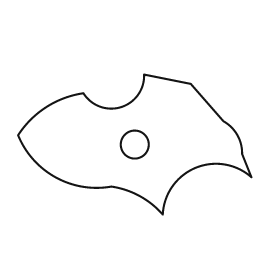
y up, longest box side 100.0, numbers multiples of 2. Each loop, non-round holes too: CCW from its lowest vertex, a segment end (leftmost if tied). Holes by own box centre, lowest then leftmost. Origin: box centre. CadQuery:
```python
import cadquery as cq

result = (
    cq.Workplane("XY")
    .moveTo(12.0, -30.0)
    .threePointArc((26.0, -10.0), (50.0, -14.0))
    .lineTo(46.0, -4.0)
    .threePointArc((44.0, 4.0), (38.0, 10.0))
    .lineTo(24.0, 26.0)
    .lineTo(4.0, 30.0)
    .threePointArc((-6.0, 16.0), (-22.0, 22.0))
    .threePointArc((-38.0, 16.0), (-50.0, 4.0))
    .threePointArc((-34.0, -14.0), (-10.0, -18.0))
    .threePointArc((2.0, -22.0), (12.0, -30.0))
    .close()
    .moveTo(0.0, 0.0)
    .circle(6.0)
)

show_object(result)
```